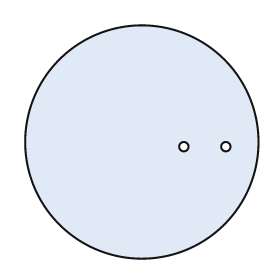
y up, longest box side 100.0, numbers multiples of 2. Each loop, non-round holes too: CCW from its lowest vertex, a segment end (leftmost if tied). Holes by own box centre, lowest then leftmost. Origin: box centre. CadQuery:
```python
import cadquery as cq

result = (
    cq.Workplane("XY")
    .moveTo(0.0, 0.0)
    .circle(50.0)
    .moveTo(18.0, -2.0)
    .circle(2.0)
    .moveTo(36.0, -2.0)
    .circle(2.0)
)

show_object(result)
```